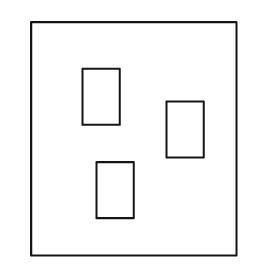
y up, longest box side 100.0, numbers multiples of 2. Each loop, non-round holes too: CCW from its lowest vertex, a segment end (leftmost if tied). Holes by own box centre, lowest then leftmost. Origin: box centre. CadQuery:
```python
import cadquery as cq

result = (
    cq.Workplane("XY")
    .moveTo(-44.0, -50.0)
    .lineTo(44.0, -50.0)
    .lineTo(44.0, 50.0)
    .lineTo(-44.0, 50.0)
    .close()
    .moveTo(-16.0, -34.0)
    .lineTo(0.0, -34.0)
    .lineTo(0.0, -10.0)
    .lineTo(-16.0, -10.0)
    .close()
    .moveTo(14.0, -8.0)
    .lineTo(30.0, -8.0)
    .lineTo(30.0, 16.0)
    .lineTo(14.0, 16.0)
    .close()
    .moveTo(-22.0, 6.0)
    .lineTo(-6.0, 6.0)
    .lineTo(-6.0, 30.0)
    .lineTo(-22.0, 30.0)
    .close()
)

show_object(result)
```